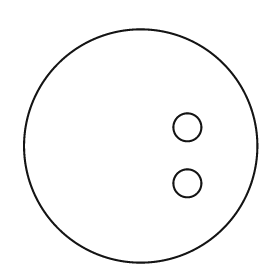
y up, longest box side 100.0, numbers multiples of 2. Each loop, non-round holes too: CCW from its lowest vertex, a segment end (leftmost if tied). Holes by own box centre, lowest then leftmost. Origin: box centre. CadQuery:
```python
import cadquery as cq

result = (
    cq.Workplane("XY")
    .moveTo(0.0, 0.0)
    .circle(50.0)
    .moveTo(20.0, -16.0)
    .circle(6.0)
    .moveTo(20.0, 8.0)
    .circle(6.0)
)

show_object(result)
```